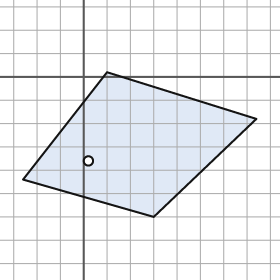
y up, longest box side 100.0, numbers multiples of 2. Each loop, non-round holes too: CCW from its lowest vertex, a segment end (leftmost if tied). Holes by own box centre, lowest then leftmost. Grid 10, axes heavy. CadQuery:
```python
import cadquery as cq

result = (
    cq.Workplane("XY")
    .moveTo(30.0, -60.0)
    .lineTo(74.0, -18.0)
    .lineTo(10.0, 2.0)
    .lineTo(-26.0, -44.0)
    .close()
    .moveTo(2.0, -36.0)
    .circle(2.0)
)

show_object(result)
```